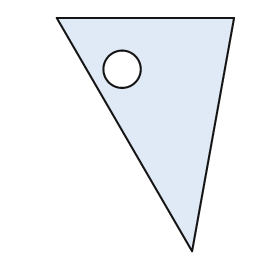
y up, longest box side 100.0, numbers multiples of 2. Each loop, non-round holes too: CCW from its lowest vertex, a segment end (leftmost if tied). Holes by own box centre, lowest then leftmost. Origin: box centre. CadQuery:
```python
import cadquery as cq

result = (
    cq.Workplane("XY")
    .moveTo(20.0, -50.0)
    .lineTo(38.0, 50.0)
    .lineTo(-38.0, 50.0)
    .close()
    .moveTo(-10.0, 28.0)
    .circle(8.0)
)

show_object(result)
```